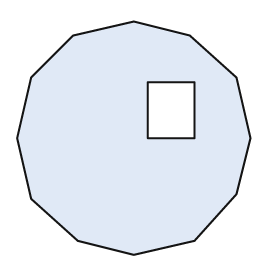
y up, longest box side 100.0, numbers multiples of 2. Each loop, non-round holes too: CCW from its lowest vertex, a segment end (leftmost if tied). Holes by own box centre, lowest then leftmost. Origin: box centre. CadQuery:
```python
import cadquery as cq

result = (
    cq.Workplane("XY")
    .moveTo(0.0, -50.0)
    .lineTo(26.0, -44.0)
    .lineTo(44.0, -24.0)
    .lineTo(50.0, 0.0)
    .lineTo(44.0, 26.0)
    .lineTo(24.0, 44.0)
    .lineTo(0.0, 50.0)
    .lineTo(-26.0, 44.0)
    .lineTo(-44.0, 26.0)
    .lineTo(-50.0, 0.0)
    .lineTo(-44.0, -26.0)
    .lineTo(-24.0, -44.0)
    .close()
    .moveTo(6.0, 0.0)
    .lineTo(26.0, 0.0)
    .lineTo(26.0, 24.0)
    .lineTo(6.0, 24.0)
    .close()
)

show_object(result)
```